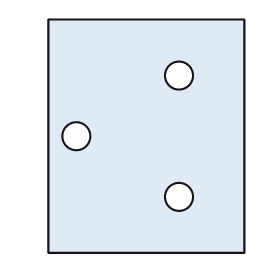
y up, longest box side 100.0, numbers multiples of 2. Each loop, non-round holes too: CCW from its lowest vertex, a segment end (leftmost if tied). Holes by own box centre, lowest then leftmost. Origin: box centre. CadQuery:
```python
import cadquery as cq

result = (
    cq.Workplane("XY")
    .moveTo(-42.0, -50.0)
    .lineTo(42.0, -50.0)
    .lineTo(42.0, 50.0)
    .lineTo(-42.0, 50.0)
    .close()
    .moveTo(14.0, -26.0)
    .circle(6.0)
    .moveTo(-30.0, 0.0)
    .circle(6.0)
    .moveTo(14.0, 26.0)
    .circle(6.0)
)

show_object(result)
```